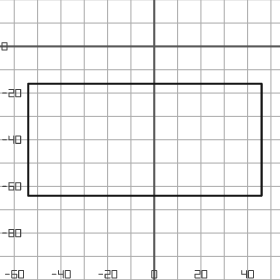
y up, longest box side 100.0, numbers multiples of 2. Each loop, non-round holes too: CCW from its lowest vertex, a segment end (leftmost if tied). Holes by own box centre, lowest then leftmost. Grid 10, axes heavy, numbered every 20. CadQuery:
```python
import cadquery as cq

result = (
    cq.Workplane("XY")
    .moveTo(-54.0, -64.0)
    .lineTo(46.0, -64.0)
    .lineTo(46.0, -16.0)
    .lineTo(-54.0, -16.0)
    .close()
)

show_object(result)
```